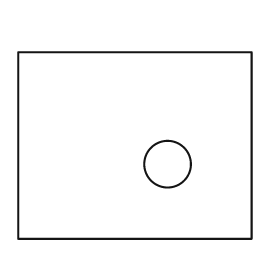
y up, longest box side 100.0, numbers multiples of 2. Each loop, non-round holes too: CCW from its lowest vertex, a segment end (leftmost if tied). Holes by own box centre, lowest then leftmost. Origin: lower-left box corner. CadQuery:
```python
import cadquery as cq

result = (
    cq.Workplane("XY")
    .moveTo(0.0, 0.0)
    .lineTo(100.0, 0.0)
    .lineTo(100.0, 80.0)
    .lineTo(0.0, 80.0)
    .close()
    .moveTo(64.0, 32.0)
    .circle(10.0)
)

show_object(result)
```